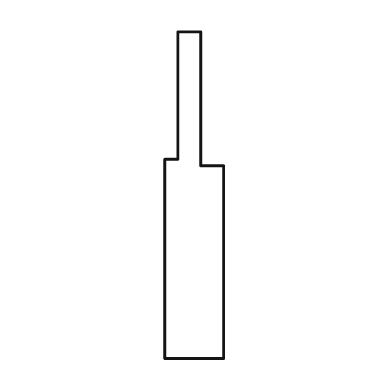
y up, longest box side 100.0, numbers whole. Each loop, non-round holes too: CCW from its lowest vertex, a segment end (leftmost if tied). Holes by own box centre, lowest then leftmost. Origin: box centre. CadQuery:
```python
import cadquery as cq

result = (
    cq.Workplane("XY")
    .moveTo(-9.0, -50.0)
    .lineTo(9.0, -50.0)
    .lineTo(9.0, 9.0)
    .lineTo(2.0, 9.0)
    .lineTo(2.0, 50.0)
    .lineTo(-5.0, 50.0)
    .lineTo(-5.0, 11.0)
    .lineTo(-9.0, 11.0)
    .close()
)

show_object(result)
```